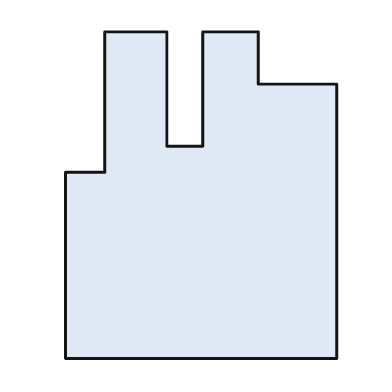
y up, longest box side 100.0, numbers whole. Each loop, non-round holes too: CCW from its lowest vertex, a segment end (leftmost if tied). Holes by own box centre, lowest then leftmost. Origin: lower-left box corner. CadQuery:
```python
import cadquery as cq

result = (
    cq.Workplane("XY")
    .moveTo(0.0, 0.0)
    .lineTo(83.0, 0.0)
    .lineTo(83.0, 84.0)
    .lineTo(59.0, 84.0)
    .lineTo(59.0, 100.0)
    .lineTo(42.0, 100.0)
    .lineTo(42.0, 65.0)
    .lineTo(31.0, 65.0)
    .lineTo(31.0, 100.0)
    .lineTo(12.0, 100.0)
    .lineTo(12.0, 57.0)
    .lineTo(0.0, 57.0)
    .close()
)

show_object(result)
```